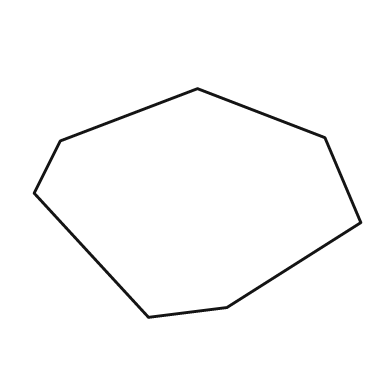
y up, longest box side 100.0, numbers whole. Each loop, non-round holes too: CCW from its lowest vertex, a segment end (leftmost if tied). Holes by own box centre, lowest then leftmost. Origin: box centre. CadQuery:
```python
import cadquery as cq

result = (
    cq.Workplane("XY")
    .moveTo(-15.0, -35.0)
    .lineTo(9.0, -32.0)
    .lineTo(50.0, -6.0)
    .lineTo(39.0, 20.0)
    .lineTo(0.0, 35.0)
    .lineTo(-42.0, 19.0)
    .lineTo(-50.0, 3.0)
    .close()
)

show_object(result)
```